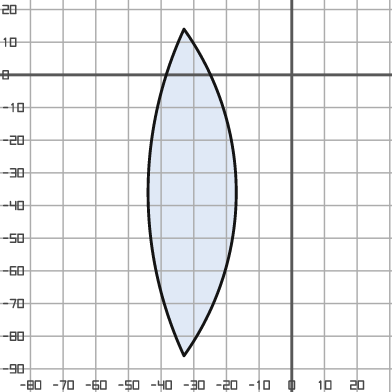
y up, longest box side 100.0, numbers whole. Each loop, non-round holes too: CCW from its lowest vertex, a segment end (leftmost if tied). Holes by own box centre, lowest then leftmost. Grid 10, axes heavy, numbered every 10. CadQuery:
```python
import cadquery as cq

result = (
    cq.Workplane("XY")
    .moveTo(-33.0, -86.0)
    .threePointArc((-17.0, -36.0), (-33.0, 14.0))
    .threePointArc((-44.0, -36.0), (-33.0, -86.0))
    .close()
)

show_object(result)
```